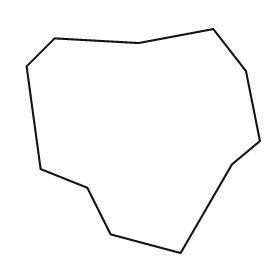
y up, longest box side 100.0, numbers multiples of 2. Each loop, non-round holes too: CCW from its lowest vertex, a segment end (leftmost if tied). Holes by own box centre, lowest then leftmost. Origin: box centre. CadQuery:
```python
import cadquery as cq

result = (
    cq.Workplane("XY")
    .moveTo(16.0, -48.0)
    .lineTo(38.0, -10.0)
    .lineTo(50.0, 0.0)
    .lineTo(44.0, 30.0)
    .lineTo(30.0, 48.0)
    .lineTo(-2.0, 42.0)
    .lineTo(-38.0, 44.0)
    .lineTo(-50.0, 32.0)
    .lineTo(-44.0, -12.0)
    .lineTo(-24.0, -20.0)
    .lineTo(-14.0, -40.0)
    .close()
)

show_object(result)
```